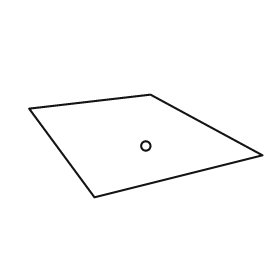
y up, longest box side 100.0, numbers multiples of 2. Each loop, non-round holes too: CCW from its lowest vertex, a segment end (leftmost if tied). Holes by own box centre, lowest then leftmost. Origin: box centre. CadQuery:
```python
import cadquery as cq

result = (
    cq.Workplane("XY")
    .moveTo(-22.0, -22.0)
    .lineTo(50.0, -4.0)
    .lineTo(2.0, 22.0)
    .lineTo(-50.0, 16.0)
    .close()
    .moveTo(0.0, 0.0)
    .circle(2.0)
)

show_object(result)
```